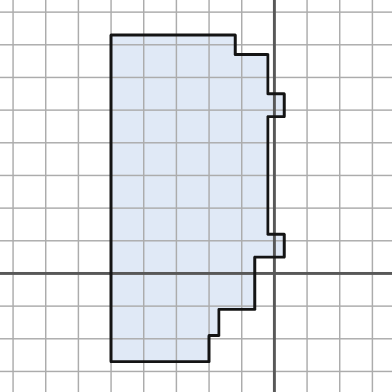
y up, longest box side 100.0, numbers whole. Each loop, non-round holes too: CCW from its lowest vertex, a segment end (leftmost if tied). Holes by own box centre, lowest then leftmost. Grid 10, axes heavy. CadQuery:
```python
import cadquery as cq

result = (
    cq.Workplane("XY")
    .moveTo(-50.0, -27.0)
    .lineTo(-20.0, -27.0)
    .lineTo(-20.0, -19.0)
    .lineTo(-17.0, -19.0)
    .lineTo(-17.0, -11.0)
    .lineTo(-6.0, -11.0)
    .lineTo(-6.0, 5.0)
    .lineTo(3.0, 5.0)
    .lineTo(3.0, 12.0)
    .lineTo(-2.0, 12.0)
    .lineTo(-2.0, 48.0)
    .lineTo(3.0, 48.0)
    .lineTo(3.0, 55.0)
    .lineTo(-2.0, 55.0)
    .lineTo(-2.0, 67.0)
    .lineTo(-12.0, 67.0)
    .lineTo(-12.0, 73.0)
    .lineTo(-50.0, 73.0)
    .close()
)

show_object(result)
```